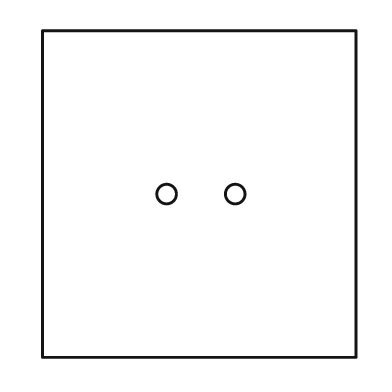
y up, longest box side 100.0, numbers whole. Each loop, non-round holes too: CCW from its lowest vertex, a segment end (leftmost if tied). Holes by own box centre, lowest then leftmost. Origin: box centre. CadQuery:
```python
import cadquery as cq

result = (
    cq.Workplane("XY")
    .moveTo(-48.0, -50.0)
    .lineTo(48.0, -50.0)
    .lineTo(48.0, 50.0)
    .lineTo(-48.0, 50.0)
    .close()
    .moveTo(-10.0, 0.0)
    .circle(3.0)
    .moveTo(11.0, 0.0)
    .circle(3.0)
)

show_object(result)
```